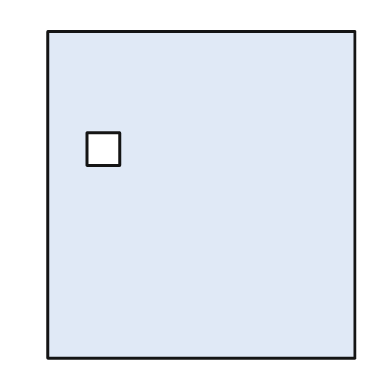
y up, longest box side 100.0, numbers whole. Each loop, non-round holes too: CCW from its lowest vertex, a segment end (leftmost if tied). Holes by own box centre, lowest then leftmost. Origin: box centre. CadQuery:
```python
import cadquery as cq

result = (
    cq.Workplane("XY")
    .moveTo(-47.0, -50.0)
    .lineTo(47.0, -50.0)
    .lineTo(47.0, 50.0)
    .lineTo(-47.0, 50.0)
    .close()
    .moveTo(-35.0, 9.0)
    .lineTo(-25.0, 9.0)
    .lineTo(-25.0, 19.0)
    .lineTo(-35.0, 19.0)
    .close()
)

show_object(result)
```